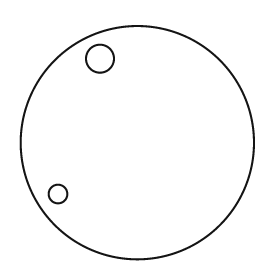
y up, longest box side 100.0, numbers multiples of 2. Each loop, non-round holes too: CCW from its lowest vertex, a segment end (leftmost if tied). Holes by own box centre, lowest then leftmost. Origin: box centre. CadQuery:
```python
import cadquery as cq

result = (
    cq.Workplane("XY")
    .moveTo(0.0, 0.0)
    .circle(50.0)
    .moveTo(-34.0, -22.0)
    .circle(4.0)
    .moveTo(-16.0, 36.0)
    .circle(6.0)
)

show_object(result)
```